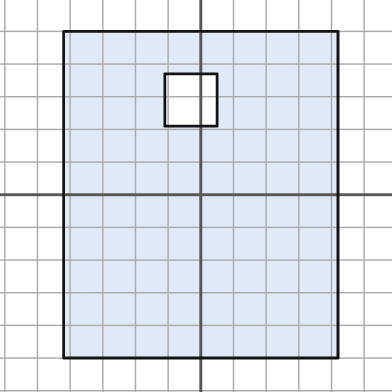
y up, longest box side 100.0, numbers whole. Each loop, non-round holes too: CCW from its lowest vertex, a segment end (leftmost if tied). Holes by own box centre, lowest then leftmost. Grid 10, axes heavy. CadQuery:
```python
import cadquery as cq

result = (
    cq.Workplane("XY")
    .moveTo(-42.0, -50.0)
    .lineTo(42.0, -50.0)
    .lineTo(42.0, 50.0)
    .lineTo(-42.0, 50.0)
    .close()
    .moveTo(-11.0, 21.0)
    .lineTo(5.0, 21.0)
    .lineTo(5.0, 37.0)
    .lineTo(-11.0, 37.0)
    .close()
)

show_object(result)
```